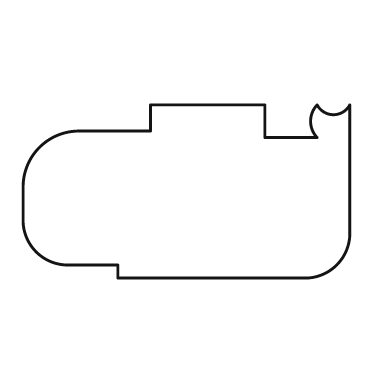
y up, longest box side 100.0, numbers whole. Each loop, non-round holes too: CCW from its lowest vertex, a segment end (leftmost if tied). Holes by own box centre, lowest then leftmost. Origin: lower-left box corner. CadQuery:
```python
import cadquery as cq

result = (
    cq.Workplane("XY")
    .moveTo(29.0, 0.0)
    .lineTo(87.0, 0.0)
    .threePointArc((96.0, 4.0), (100.0, 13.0))
    .lineTo(100.0, 53.0)
    .threePointArc((95.0, 50.0), (90.0, 53.0))
    .threePointArc((88.0, 48.0), (90.0, 43.0))
    .lineTo(74.0, 43.0)
    .lineTo(74.0, 53.0)
    .lineTo(39.0, 53.0)
    .lineTo(39.0, 45.0)
    .lineTo(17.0, 45.0)
    .threePointArc((5.0, 40.0), (0.0, 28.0))
    .lineTo(0.0, 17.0)
    .threePointArc((4.0, 8.0), (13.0, 4.0))
    .lineTo(29.0, 4.0)
    .close()
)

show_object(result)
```